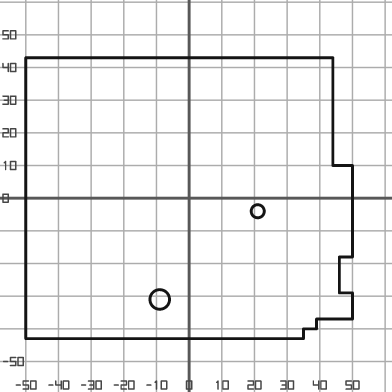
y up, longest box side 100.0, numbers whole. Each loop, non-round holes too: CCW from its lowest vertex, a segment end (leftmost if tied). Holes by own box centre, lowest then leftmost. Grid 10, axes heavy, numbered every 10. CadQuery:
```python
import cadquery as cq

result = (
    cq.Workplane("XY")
    .moveTo(-50.0, -43.0)
    .lineTo(35.0, -43.0)
    .lineTo(35.0, -40.0)
    .lineTo(39.0, -40.0)
    .lineTo(39.0, -37.0)
    .lineTo(50.0, -37.0)
    .lineTo(50.0, -29.0)
    .lineTo(46.0, -29.0)
    .lineTo(46.0, -18.0)
    .lineTo(50.0, -18.0)
    .lineTo(50.0, 10.0)
    .lineTo(44.0, 10.0)
    .lineTo(44.0, 43.0)
    .lineTo(-50.0, 43.0)
    .close()
    .moveTo(-9.0, -31.0)
    .circle(3.0)
    .moveTo(21.0, -4.0)
    .circle(2.0)
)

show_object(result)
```